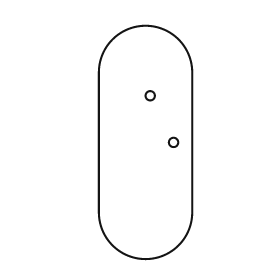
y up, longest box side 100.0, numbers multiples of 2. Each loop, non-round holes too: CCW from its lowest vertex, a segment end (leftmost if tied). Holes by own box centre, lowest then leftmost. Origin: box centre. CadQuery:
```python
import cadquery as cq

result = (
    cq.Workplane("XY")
    .moveTo(-20.0, -30.0)
    .threePointArc((0.0, -50.0), (20.0, -30.0))
    .lineTo(20.0, 30.0)
    .threePointArc((0.0, 50.0), (-20.0, 30.0))
    .close()
    .moveTo(12.0, 0.0)
    .circle(2.0)
    .moveTo(2.0, 20.0)
    .circle(2.0)
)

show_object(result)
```